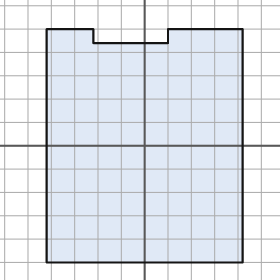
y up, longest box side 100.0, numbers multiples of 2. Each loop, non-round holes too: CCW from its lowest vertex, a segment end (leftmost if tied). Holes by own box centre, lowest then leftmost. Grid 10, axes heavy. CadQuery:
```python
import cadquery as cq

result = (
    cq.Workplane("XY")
    .moveTo(-42.0, -50.0)
    .lineTo(42.0, -50.0)
    .lineTo(42.0, 50.0)
    .lineTo(10.0, 50.0)
    .lineTo(10.0, 44.0)
    .lineTo(-22.0, 44.0)
    .lineTo(-22.0, 50.0)
    .lineTo(-42.0, 50.0)
    .close()
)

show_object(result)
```